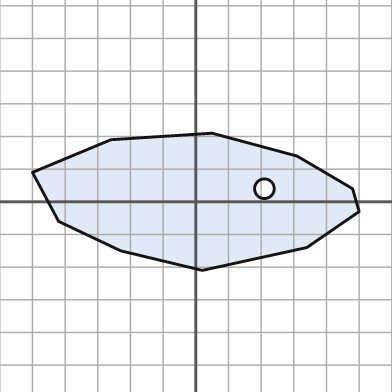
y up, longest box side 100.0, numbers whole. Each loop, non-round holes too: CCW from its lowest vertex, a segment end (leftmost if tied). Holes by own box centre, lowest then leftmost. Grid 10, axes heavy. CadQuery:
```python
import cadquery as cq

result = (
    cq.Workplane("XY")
    .moveTo(2.0, -21.0)
    .lineTo(34.0, -14.0)
    .lineTo(50.0, -3.0)
    .lineTo(48.0, 4.0)
    .lineTo(31.0, 14.0)
    .lineTo(5.0, 21.0)
    .lineTo(-26.0, 19.0)
    .lineTo(-50.0, 9.0)
    .lineTo(-42.0, -6.0)
    .lineTo(-23.0, -15.0)
    .close()
    .moveTo(21.0, 4.0)
    .circle(3.0)
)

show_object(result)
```